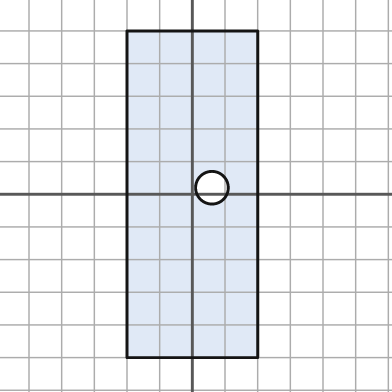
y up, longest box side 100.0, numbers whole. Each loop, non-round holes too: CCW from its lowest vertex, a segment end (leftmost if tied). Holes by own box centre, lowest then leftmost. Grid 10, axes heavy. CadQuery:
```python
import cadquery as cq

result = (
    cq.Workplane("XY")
    .moveTo(-20.0, -50.0)
    .lineTo(20.0, -50.0)
    .lineTo(20.0, 50.0)
    .lineTo(-20.0, 50.0)
    .close()
    .moveTo(6.0, 2.0)
    .circle(5.0)
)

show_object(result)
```